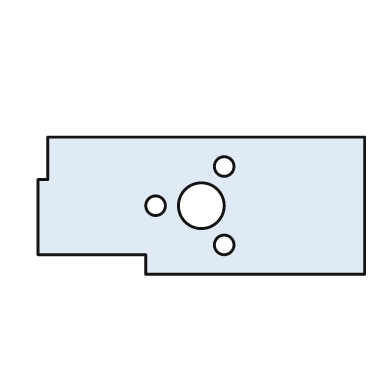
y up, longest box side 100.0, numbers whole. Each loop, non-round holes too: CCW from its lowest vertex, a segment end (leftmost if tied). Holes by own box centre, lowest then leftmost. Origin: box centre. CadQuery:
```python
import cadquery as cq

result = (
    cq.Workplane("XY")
    .moveTo(-17.0, -21.0)
    .lineTo(50.0, -21.0)
    .lineTo(50.0, 21.0)
    .lineTo(-47.0, 21.0)
    .lineTo(-47.0, 8.0)
    .lineTo(-50.0, 8.0)
    .lineTo(-50.0, -15.0)
    .lineTo(-17.0, -15.0)
    .close()
    .moveTo(7.0, -12.0)
    .circle(3.0)
    .moveTo(-14.0, 0.0)
    .circle(3.0)
    .moveTo(0.0, 0.0)
    .circle(7.0)
    .moveTo(7.0, 12.0)
    .circle(3.0)
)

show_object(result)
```